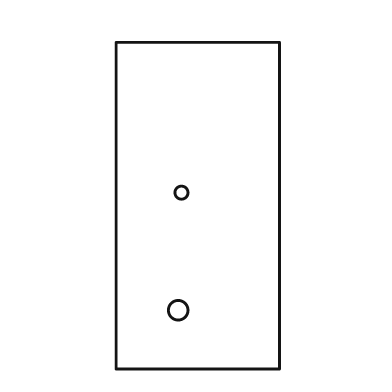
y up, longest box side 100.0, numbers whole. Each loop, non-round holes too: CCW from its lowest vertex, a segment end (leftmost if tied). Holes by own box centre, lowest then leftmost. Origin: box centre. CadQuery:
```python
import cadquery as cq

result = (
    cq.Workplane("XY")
    .moveTo(-25.0, -50.0)
    .lineTo(25.0, -50.0)
    .lineTo(25.0, 50.0)
    .lineTo(-25.0, 50.0)
    .close()
    .moveTo(-6.0, -32.0)
    .circle(3.0)
    .moveTo(-5.0, 4.0)
    .circle(2.0)
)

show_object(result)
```